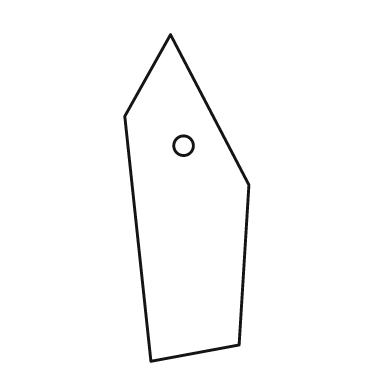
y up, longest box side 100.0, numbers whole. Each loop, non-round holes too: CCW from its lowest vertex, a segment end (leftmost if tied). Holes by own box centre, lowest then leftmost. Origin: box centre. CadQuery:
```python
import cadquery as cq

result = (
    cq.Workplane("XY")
    .moveTo(-11.0, -50.0)
    .lineTo(16.0, -45.0)
    .lineTo(19.0, 4.0)
    .lineTo(-5.0, 50.0)
    .lineTo(-19.0, 25.0)
    .close()
    .moveTo(-1.0, 16.0)
    .circle(3.0)
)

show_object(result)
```